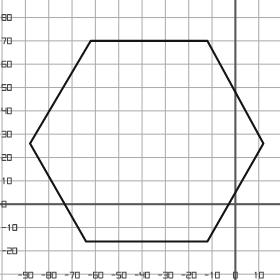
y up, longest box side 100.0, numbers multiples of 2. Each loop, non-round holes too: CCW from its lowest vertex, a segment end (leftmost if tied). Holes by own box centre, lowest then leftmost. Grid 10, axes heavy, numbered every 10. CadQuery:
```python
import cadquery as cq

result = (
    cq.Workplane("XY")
    .moveTo(-64.0, -16.0)
    .lineTo(-12.0, -16.0)
    .lineTo(12.0, 26.0)
    .lineTo(-12.0, 70.0)
    .lineTo(-62.0, 70.0)
    .lineTo(-88.0, 26.0)
    .close()
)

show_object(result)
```